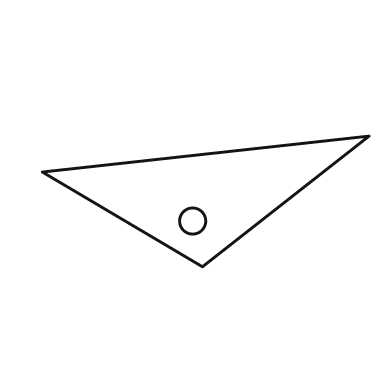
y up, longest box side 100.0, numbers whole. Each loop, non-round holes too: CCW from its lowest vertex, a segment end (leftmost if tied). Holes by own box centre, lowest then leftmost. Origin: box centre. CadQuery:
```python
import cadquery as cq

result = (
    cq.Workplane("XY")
    .moveTo(-1.0, -20.0)
    .lineTo(50.0, 20.0)
    .lineTo(-50.0, 9.0)
    .close()
    .moveTo(-4.0, -6.0)
    .circle(4.0)
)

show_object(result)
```